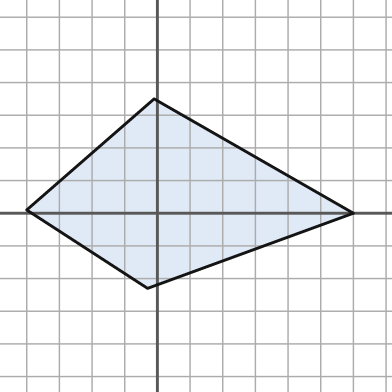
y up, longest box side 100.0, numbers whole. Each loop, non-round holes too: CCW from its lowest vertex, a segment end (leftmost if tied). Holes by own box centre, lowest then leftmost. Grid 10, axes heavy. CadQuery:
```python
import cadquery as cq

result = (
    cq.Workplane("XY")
    .moveTo(-3.0, -23.0)
    .lineTo(60.0, 0.0)
    .lineTo(-1.0, 35.0)
    .lineTo(-40.0, 1.0)
    .close()
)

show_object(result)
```